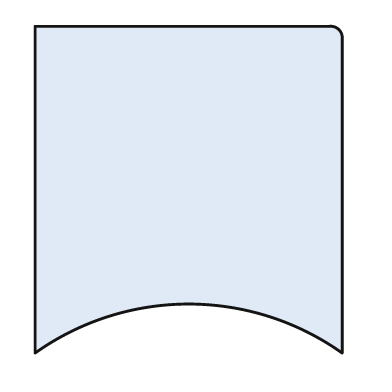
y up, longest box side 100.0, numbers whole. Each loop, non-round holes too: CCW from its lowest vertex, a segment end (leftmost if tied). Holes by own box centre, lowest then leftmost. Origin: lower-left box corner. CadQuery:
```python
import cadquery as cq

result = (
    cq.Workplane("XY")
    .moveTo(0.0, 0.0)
    .threePointArc((47.0, 15.0), (94.0, 0.0))
    .lineTo(94.0, 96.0)
    .threePointArc((93.0, 99.0), (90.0, 100.0))
    .lineTo(0.0, 100.0)
    .close()
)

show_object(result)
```